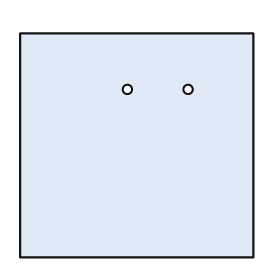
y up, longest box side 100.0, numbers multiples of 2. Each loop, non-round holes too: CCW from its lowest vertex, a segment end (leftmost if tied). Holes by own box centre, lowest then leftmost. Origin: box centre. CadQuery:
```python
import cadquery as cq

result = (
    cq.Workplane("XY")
    .moveTo(-50.0, -48.0)
    .lineTo(50.0, -48.0)
    .lineTo(50.0, 48.0)
    .lineTo(-50.0, 48.0)
    .close()
    .moveTo(-4.0, 24.0)
    .circle(2.0)
    .moveTo(22.0, 24.0)
    .circle(2.0)
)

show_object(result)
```